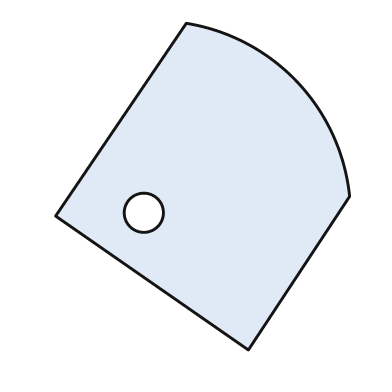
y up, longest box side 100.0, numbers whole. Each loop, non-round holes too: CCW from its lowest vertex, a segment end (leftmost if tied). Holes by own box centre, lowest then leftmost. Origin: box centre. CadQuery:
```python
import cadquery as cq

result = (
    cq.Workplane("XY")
    .moveTo(14.0, -50.0)
    .lineTo(45.0, -3.0)
    .threePointArc((29.0, 32.0), (-5.0, 50.0))
    .lineTo(-45.0, -9.0)
    .close()
    .moveTo(-18.0, -8.0)
    .circle(6.0)
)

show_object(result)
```